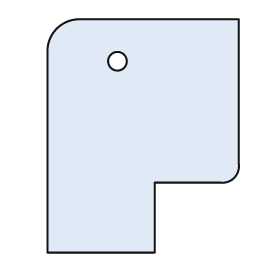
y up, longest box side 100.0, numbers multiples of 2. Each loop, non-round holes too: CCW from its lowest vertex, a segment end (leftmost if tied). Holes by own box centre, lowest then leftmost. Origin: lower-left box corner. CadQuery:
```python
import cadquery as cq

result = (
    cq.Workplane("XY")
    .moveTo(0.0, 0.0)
    .lineTo(46.0, 0.0)
    .lineTo(46.0, 30.0)
    .lineTo(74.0, 30.0)
    .threePointArc((80.0, 32.0), (82.0, 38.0))
    .lineTo(82.0, 100.0)
    .lineTo(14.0, 100.0)
    .threePointArc((4.0, 96.0), (0.0, 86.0))
    .close()
    .moveTo(30.0, 82.0)
    .circle(4.0)
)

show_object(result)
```